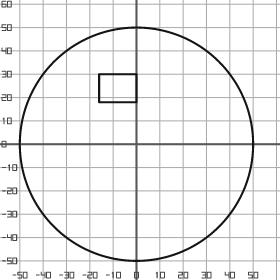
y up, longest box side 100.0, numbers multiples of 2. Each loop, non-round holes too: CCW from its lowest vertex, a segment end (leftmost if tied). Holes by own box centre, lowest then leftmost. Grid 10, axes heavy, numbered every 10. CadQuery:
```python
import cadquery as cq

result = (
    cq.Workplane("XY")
    .moveTo(0.0, 0.0)
    .circle(50.0)
    .moveTo(-16.0, 18.0)
    .lineTo(0.0, 18.0)
    .lineTo(0.0, 30.0)
    .lineTo(-16.0, 30.0)
    .close()
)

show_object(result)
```